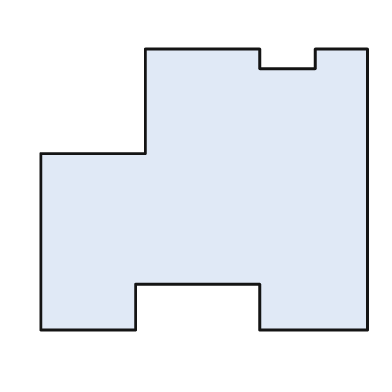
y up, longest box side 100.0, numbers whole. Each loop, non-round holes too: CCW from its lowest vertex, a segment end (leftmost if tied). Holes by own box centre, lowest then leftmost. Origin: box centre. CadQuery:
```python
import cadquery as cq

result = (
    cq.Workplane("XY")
    .moveTo(-50.0, -43.0)
    .lineTo(-21.0, -43.0)
    .lineTo(-21.0, -29.0)
    .lineTo(17.0, -29.0)
    .lineTo(17.0, -43.0)
    .lineTo(50.0, -43.0)
    .lineTo(50.0, 43.0)
    .lineTo(34.0, 43.0)
    .lineTo(34.0, 37.0)
    .lineTo(17.0, 37.0)
    .lineTo(17.0, 43.0)
    .lineTo(-18.0, 43.0)
    .lineTo(-18.0, 11.0)
    .lineTo(-50.0, 11.0)
    .close()
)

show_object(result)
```